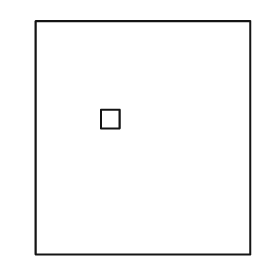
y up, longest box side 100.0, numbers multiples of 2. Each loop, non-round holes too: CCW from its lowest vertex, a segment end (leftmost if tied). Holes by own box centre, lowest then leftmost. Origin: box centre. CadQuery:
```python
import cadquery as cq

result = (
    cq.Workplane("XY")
    .moveTo(-46.0, -50.0)
    .lineTo(46.0, -50.0)
    .lineTo(46.0, 50.0)
    .lineTo(-46.0, 50.0)
    .close()
    .moveTo(-18.0, 4.0)
    .lineTo(-10.0, 4.0)
    .lineTo(-10.0, 12.0)
    .lineTo(-18.0, 12.0)
    .close()
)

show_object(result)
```